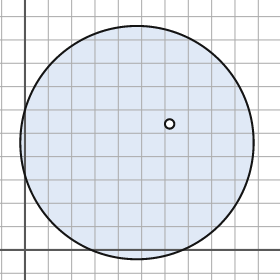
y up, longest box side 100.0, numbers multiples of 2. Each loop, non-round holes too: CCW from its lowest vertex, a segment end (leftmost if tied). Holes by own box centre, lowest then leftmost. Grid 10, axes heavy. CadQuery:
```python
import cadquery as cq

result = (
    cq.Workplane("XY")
    .moveTo(48.0, 46.0)
    .circle(50.0)
    .moveTo(62.0, 54.0)
    .circle(2.0)
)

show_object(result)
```